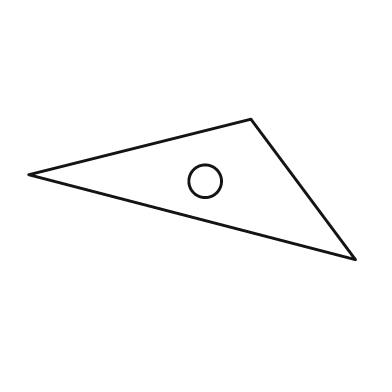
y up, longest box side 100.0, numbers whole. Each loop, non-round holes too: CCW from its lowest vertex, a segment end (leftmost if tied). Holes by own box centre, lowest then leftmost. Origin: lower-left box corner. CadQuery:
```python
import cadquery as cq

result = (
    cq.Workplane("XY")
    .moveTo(100.0, 0.0)
    .lineTo(68.0, 43.0)
    .lineTo(0.0, 26.0)
    .close()
    .moveTo(54.0, 24.0)
    .circle(5.0)
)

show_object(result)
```